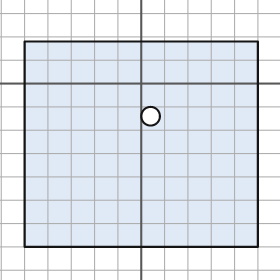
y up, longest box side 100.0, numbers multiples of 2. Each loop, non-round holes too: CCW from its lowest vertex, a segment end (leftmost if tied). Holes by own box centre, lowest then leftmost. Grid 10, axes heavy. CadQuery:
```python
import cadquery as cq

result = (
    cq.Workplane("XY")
    .moveTo(-50.0, -70.0)
    .lineTo(50.0, -70.0)
    .lineTo(50.0, 18.0)
    .lineTo(-50.0, 18.0)
    .close()
    .moveTo(4.0, -14.0)
    .circle(4.0)
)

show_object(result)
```